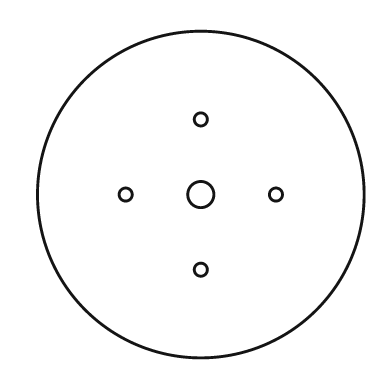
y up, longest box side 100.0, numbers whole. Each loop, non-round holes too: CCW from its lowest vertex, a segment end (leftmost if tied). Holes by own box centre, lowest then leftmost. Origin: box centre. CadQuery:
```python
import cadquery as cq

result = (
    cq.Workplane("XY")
    .moveTo(0.0, 0.0)
    .circle(50.0)
    .moveTo(0.0, -23.0)
    .circle(2.0)
    .moveTo(-23.0, 0.0)
    .circle(2.0)
    .moveTo(0.0, 0.0)
    .circle(4.0)
    .moveTo(23.0, 0.0)
    .circle(2.0)
    .moveTo(0.0, 23.0)
    .circle(2.0)
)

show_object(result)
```